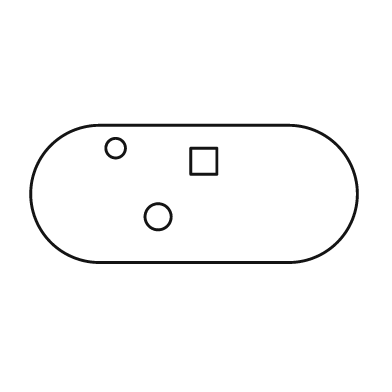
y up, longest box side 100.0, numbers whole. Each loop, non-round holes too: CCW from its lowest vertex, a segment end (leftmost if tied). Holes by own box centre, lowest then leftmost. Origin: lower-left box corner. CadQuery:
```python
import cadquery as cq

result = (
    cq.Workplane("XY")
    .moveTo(21.0, 0.0)
    .lineTo(79.0, 0.0)
    .threePointArc((100.0, 21.0), (79.0, 42.0))
    .lineTo(21.0, 42.0)
    .threePointArc((0.0, 21.0), (21.0, 0.0))
    .close()
    .moveTo(39.0, 14.0)
    .circle(4.0)
    .moveTo(49.0, 27.0)
    .lineTo(57.0, 27.0)
    .lineTo(57.0, 35.0)
    .lineTo(49.0, 35.0)
    .close()
    .moveTo(26.0, 35.0)
    .circle(3.0)
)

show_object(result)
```